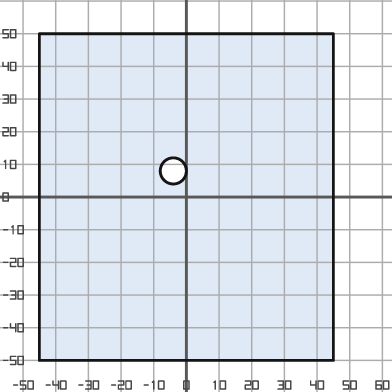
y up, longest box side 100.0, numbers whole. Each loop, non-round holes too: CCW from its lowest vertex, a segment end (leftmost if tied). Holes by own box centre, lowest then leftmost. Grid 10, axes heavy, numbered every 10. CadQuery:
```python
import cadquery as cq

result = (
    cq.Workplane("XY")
    .moveTo(-45.0, -50.0)
    .lineTo(45.0, -50.0)
    .lineTo(45.0, 50.0)
    .lineTo(-45.0, 50.0)
    .close()
    .moveTo(-4.0, 8.0)
    .circle(4.0)
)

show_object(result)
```